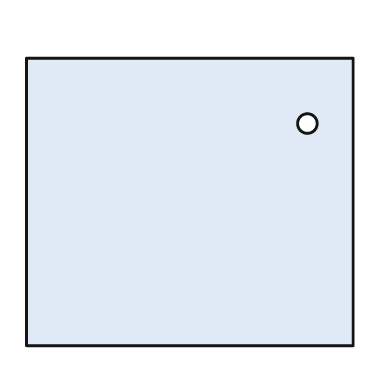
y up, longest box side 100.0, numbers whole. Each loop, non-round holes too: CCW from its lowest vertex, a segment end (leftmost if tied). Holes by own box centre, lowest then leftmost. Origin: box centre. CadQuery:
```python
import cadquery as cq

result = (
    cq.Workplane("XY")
    .moveTo(-50.0, -44.0)
    .lineTo(50.0, -44.0)
    .lineTo(50.0, 44.0)
    .lineTo(-50.0, 44.0)
    .close()
    .moveTo(36.0, 24.0)
    .circle(3.0)
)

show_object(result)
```